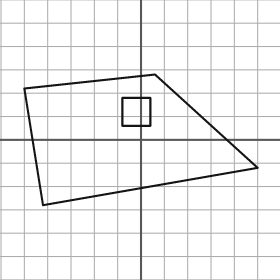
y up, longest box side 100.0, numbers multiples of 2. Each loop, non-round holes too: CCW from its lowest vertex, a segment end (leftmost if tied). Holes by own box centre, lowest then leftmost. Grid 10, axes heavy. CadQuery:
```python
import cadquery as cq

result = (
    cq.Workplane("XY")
    .moveTo(-42.0, -28.0)
    .lineTo(50.0, -12.0)
    .lineTo(6.0, 28.0)
    .lineTo(-50.0, 22.0)
    .close()
    .moveTo(-8.0, 6.0)
    .lineTo(4.0, 6.0)
    .lineTo(4.0, 18.0)
    .lineTo(-8.0, 18.0)
    .close()
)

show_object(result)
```